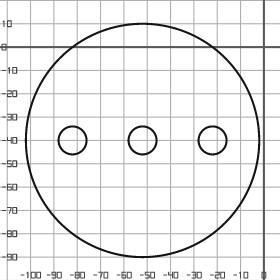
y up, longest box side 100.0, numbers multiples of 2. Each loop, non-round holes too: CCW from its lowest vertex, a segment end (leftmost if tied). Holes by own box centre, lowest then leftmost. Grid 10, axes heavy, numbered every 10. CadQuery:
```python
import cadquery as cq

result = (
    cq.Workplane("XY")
    .moveTo(-52.0, -40.0)
    .circle(50.0)
    .moveTo(-82.0, -40.0)
    .circle(6.0)
    .moveTo(-52.0, -40.0)
    .circle(6.0)
    .moveTo(-22.0, -40.0)
    .circle(6.0)
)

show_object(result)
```